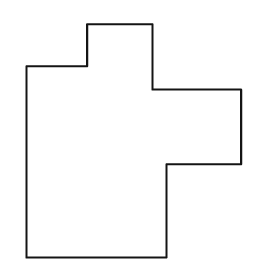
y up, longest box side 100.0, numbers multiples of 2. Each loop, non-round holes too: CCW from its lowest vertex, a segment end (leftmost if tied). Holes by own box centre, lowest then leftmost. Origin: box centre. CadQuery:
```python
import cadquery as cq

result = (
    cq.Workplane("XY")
    .moveTo(-46.0, -50.0)
    .lineTo(14.0, -50.0)
    .lineTo(14.0, -10.0)
    .lineTo(46.0, -10.0)
    .lineTo(46.0, 22.0)
    .lineTo(8.0, 22.0)
    .lineTo(8.0, 50.0)
    .lineTo(-20.0, 50.0)
    .lineTo(-20.0, 32.0)
    .lineTo(-46.0, 32.0)
    .close()
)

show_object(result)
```